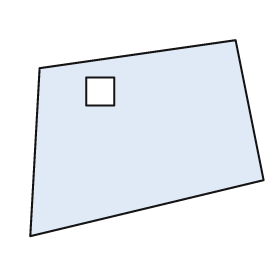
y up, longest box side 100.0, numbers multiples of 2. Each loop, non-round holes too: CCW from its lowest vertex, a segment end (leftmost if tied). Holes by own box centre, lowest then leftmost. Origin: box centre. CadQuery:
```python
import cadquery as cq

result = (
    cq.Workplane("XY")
    .moveTo(-50.0, -42.0)
    .lineTo(50.0, -18.0)
    .lineTo(38.0, 42.0)
    .lineTo(-46.0, 30.0)
    .close()
    .moveTo(-26.0, 14.0)
    .lineTo(-14.0, 14.0)
    .lineTo(-14.0, 26.0)
    .lineTo(-26.0, 26.0)
    .close()
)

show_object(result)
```